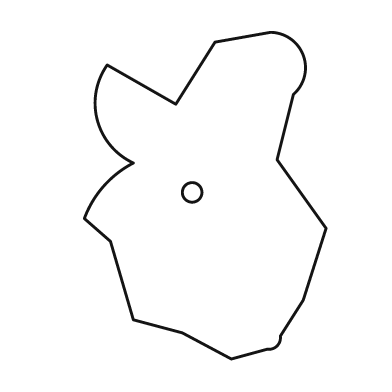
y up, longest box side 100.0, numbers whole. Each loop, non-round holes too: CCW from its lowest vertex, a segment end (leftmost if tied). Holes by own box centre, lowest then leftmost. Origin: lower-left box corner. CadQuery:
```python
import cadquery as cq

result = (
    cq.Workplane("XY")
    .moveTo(45.0, 0.0)
    .lineTo(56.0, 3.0)
    .threePointArc((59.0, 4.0), (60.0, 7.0))
    .lineTo(67.0, 18.0)
    .lineTo(74.0, 40.0)
    .lineTo(59.0, 61.0)
    .lineTo(64.0, 81.0)
    .threePointArc((67.0, 93.0), (57.0, 100.0))
    .lineTo(40.0, 97.0)
    .lineTo(28.0, 78.0)
    .lineTo(7.0, 90.0)
    .threePointArc((4.0, 73.0), (15.0, 60.0))
    .threePointArc((6.0, 53.0), (0.0, 43.0))
    .lineTo(8.0, 36.0)
    .lineTo(15.0, 12.0)
    .lineTo(30.0, 8.0)
    .close()
    .moveTo(33.0, 51.0)
    .circle(3.0)
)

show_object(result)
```